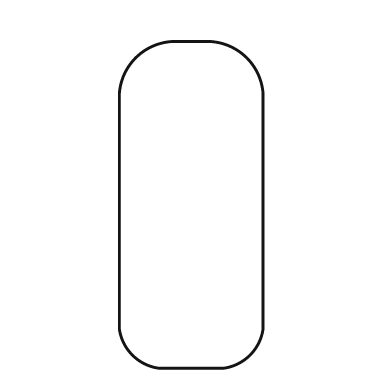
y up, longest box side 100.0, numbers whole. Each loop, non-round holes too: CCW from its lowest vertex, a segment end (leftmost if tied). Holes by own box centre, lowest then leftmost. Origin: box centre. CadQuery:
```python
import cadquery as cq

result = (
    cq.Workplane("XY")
    .moveTo(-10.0, -50.0)
    .lineTo(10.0, -50.0)
    .threePointArc((18.0, -46.0), (22.0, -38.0))
    .lineTo(22.0, 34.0)
    .threePointArc((17.0, 45.0), (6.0, 50.0))
    .lineTo(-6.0, 50.0)
    .threePointArc((-17.0, 45.0), (-22.0, 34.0))
    .lineTo(-22.0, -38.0)
    .threePointArc((-18.0, -46.0), (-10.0, -50.0))
    .close()
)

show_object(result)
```